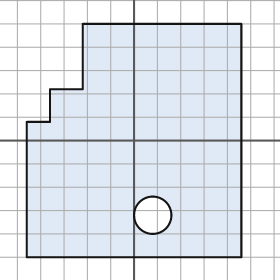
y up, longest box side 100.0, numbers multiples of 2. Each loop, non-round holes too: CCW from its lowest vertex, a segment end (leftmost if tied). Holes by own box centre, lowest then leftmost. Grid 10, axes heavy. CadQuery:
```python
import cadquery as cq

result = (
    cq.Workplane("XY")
    .moveTo(-46.0, -50.0)
    .lineTo(46.0, -50.0)
    .lineTo(46.0, 50.0)
    .lineTo(-22.0, 50.0)
    .lineTo(-22.0, 22.0)
    .lineTo(-36.0, 22.0)
    .lineTo(-36.0, 8.0)
    .lineTo(-46.0, 8.0)
    .close()
    .moveTo(8.0, -32.0)
    .circle(8.0)
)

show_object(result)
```